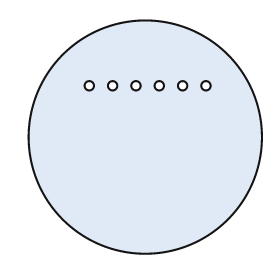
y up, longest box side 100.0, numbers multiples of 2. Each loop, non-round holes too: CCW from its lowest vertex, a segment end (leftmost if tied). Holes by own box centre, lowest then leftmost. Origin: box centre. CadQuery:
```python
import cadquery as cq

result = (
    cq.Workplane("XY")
    .moveTo(0.0, 0.0)
    .circle(50.0)
    .moveTo(-24.0, 22.0)
    .circle(2.0)
    .moveTo(-14.0, 22.0)
    .circle(2.0)
    .moveTo(-4.0, 22.0)
    .circle(2.0)
    .moveTo(6.0, 22.0)
    .circle(2.0)
    .moveTo(16.0, 22.0)
    .circle(2.0)
    .moveTo(26.0, 22.0)
    .circle(2.0)
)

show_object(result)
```